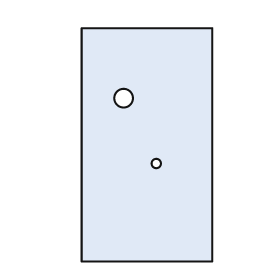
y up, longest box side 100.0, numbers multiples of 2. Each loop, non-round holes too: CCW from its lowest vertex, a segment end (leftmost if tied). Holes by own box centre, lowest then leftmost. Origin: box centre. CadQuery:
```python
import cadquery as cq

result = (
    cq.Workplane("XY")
    .moveTo(-28.0, -50.0)
    .lineTo(28.0, -50.0)
    .lineTo(28.0, 50.0)
    .lineTo(-28.0, 50.0)
    .close()
    .moveTo(4.0, -8.0)
    .circle(2.0)
    .moveTo(-10.0, 20.0)
    .circle(4.0)
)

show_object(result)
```